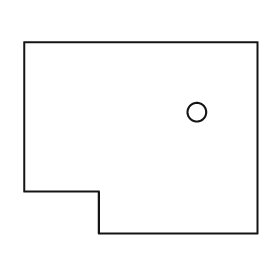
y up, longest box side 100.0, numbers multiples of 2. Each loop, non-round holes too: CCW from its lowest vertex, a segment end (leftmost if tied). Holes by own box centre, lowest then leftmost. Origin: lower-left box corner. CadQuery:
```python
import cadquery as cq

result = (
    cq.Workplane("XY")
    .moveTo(32.0, 0.0)
    .lineTo(100.0, 0.0)
    .lineTo(100.0, 82.0)
    .lineTo(0.0, 82.0)
    .lineTo(0.0, 18.0)
    .lineTo(32.0, 18.0)
    .close()
    .moveTo(74.0, 52.0)
    .circle(4.0)
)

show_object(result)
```